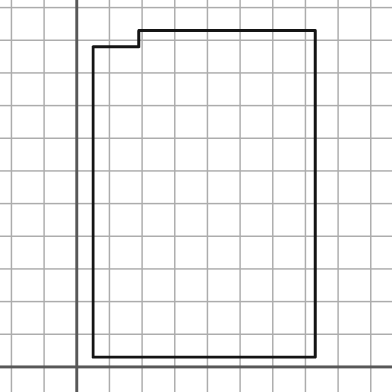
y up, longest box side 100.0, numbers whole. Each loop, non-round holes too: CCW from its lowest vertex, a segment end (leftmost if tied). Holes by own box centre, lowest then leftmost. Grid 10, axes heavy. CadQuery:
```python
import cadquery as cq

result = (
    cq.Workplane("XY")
    .moveTo(5.0, 3.0)
    .lineTo(73.0, 3.0)
    .lineTo(73.0, 103.0)
    .lineTo(19.0, 103.0)
    .lineTo(19.0, 98.0)
    .lineTo(5.0, 98.0)
    .close()
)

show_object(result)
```